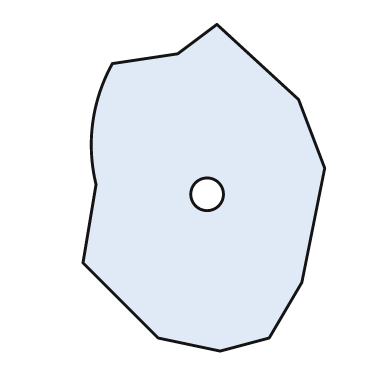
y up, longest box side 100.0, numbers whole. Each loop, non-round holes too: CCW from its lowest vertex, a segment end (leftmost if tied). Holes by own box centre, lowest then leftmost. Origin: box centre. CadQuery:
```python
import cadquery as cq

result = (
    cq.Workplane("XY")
    .moveTo(5.0, -50.0)
    .lineTo(20.0, -46.0)
    .lineTo(30.0, -29.0)
    .lineTo(37.0, 6.0)
    .lineTo(29.0, 27.0)
    .lineTo(4.0, 50.0)
    .lineTo(-8.0, 41.0)
    .lineTo(-28.0, 38.0)
    .threePointArc((-34.0, 20.0), (-33.0, 1.0))
    .lineTo(-37.0, -23.0)
    .lineTo(-14.0, -46.0)
    .close()
    .moveTo(1.0, -2.0)
    .circle(5.0)
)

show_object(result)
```